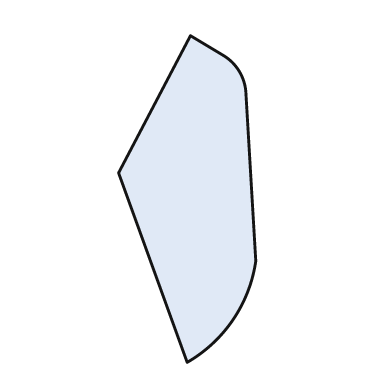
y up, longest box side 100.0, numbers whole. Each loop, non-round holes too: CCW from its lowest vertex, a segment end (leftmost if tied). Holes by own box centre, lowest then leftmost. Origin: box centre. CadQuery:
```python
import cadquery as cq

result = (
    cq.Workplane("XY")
    .moveTo(0.0, -50.0)
    .threePointArc((14.0, -37.0), (21.0, -19.0))
    .lineTo(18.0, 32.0)
    .threePointArc((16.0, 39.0), (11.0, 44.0))
    .lineTo(1.0, 50.0)
    .lineTo(-21.0, 8.0)
    .close()
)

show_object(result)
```